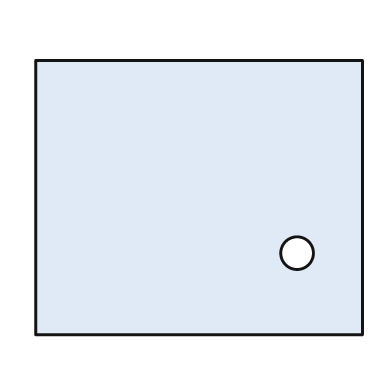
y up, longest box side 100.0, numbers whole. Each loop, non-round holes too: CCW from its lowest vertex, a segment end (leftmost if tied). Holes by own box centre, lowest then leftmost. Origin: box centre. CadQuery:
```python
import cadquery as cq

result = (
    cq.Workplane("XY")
    .moveTo(-50.0, -42.0)
    .lineTo(50.0, -42.0)
    .lineTo(50.0, 42.0)
    .lineTo(-50.0, 42.0)
    .close()
    .moveTo(30.0, -17.0)
    .circle(5.0)
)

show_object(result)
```